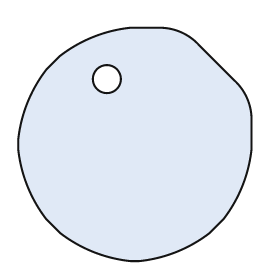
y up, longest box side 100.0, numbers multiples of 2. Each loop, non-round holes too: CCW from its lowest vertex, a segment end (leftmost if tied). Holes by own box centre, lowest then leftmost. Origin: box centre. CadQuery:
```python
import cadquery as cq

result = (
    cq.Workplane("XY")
    .moveTo(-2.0, -50.0)
    .lineTo(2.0, -50.0)
    .threePointArc((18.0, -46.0), (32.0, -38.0))
    .lineTo(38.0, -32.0)
    .threePointArc((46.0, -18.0), (50.0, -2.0))
    .lineTo(50.0, 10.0)
    .threePointArc((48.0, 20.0), (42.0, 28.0))
    .lineTo(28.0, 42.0)
    .threePointArc((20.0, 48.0), (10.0, 50.0))
    .lineTo(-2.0, 50.0)
    .threePointArc((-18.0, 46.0), (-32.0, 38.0))
    .lineTo(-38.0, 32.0)
    .threePointArc((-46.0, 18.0), (-50.0, 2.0))
    .lineTo(-50.0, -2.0)
    .threePointArc((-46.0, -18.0), (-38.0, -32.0))
    .lineTo(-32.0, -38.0)
    .threePointArc((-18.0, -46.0), (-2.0, -50.0))
    .close()
    .moveTo(-12.0, 28.0)
    .circle(6.0)
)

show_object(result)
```